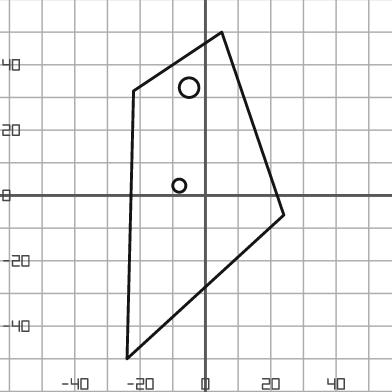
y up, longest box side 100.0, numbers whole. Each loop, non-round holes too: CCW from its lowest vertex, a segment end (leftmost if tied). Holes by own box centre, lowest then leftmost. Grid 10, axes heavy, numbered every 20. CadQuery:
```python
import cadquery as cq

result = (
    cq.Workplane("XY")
    .moveTo(-24.0, -50.0)
    .lineTo(24.0, -6.0)
    .lineTo(5.0, 50.0)
    .lineTo(-22.0, 32.0)
    .close()
    .moveTo(-8.0, 3.0)
    .circle(2.0)
    .moveTo(-5.0, 33.0)
    .circle(3.0)
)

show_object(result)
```